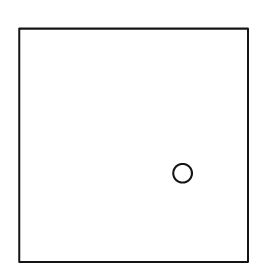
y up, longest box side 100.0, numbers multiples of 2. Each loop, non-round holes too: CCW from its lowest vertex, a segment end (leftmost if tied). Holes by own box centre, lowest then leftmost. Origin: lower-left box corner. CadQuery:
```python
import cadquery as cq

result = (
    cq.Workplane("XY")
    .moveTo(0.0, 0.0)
    .lineTo(98.0, 0.0)
    .lineTo(98.0, 100.0)
    .lineTo(0.0, 100.0)
    .close()
    .moveTo(70.0, 38.0)
    .circle(4.0)
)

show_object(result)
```